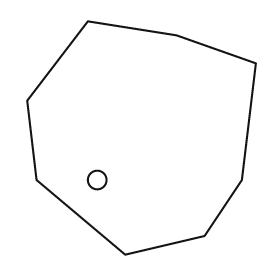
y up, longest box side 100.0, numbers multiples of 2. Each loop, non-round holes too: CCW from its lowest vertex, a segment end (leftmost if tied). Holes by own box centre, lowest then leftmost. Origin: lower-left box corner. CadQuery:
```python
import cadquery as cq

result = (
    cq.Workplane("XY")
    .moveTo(42.0, 0.0)
    .lineTo(76.0, 8.0)
    .lineTo(92.0, 32.0)
    .lineTo(98.0, 82.0)
    .lineTo(64.0, 94.0)
    .lineTo(26.0, 100.0)
    .lineTo(0.0, 66.0)
    .lineTo(4.0, 32.0)
    .close()
    .moveTo(30.0, 32.0)
    .circle(4.0)
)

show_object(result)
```